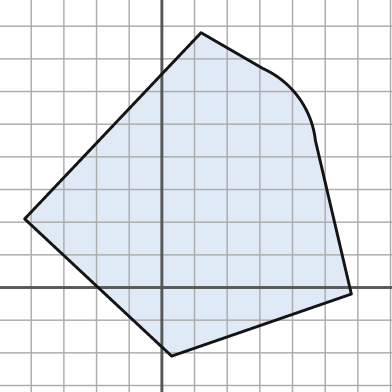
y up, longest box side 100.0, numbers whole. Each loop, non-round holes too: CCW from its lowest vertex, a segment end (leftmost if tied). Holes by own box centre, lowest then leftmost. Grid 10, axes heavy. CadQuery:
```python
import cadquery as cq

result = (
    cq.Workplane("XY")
    .moveTo(3.0, -21.0)
    .lineTo(58.0, -2.0)
    .lineTo(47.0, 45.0)
    .threePointArc((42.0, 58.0), (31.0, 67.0))
    .lineTo(12.0, 78.0)
    .lineTo(-42.0, 21.0)
    .close()
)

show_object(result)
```